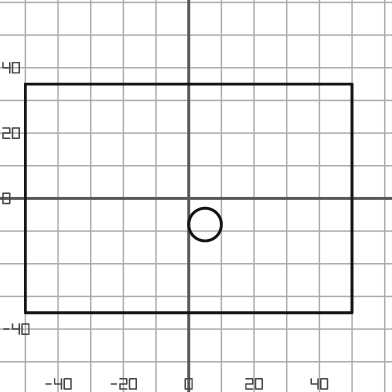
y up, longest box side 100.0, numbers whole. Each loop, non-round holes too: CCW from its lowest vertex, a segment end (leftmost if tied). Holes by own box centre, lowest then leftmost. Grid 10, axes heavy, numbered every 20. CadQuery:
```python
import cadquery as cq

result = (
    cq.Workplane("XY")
    .moveTo(-50.0, -35.0)
    .lineTo(50.0, -35.0)
    .lineTo(50.0, 35.0)
    .lineTo(-50.0, 35.0)
    .close()
    .moveTo(5.0, -8.0)
    .circle(5.0)
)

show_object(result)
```